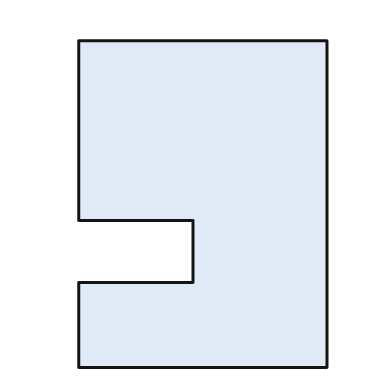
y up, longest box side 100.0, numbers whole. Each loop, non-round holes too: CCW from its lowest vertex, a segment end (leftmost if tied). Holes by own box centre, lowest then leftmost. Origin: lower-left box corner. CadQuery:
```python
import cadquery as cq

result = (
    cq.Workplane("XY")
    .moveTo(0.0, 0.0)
    .lineTo(76.0, 0.0)
    .lineTo(76.0, 100.0)
    .lineTo(0.0, 100.0)
    .lineTo(0.0, 45.0)
    .lineTo(35.0, 45.0)
    .lineTo(35.0, 26.0)
    .lineTo(0.0, 26.0)
    .close()
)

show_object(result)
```